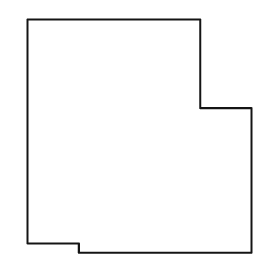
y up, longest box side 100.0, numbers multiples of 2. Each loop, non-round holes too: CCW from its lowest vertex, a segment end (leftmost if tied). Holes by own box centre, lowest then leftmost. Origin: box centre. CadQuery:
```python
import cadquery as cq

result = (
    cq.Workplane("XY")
    .moveTo(-26.0, -50.0)
    .lineTo(48.0, -50.0)
    .lineTo(48.0, 12.0)
    .lineTo(26.0, 12.0)
    .lineTo(26.0, 50.0)
    .lineTo(-48.0, 50.0)
    .lineTo(-48.0, -46.0)
    .lineTo(-26.0, -46.0)
    .close()
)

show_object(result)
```